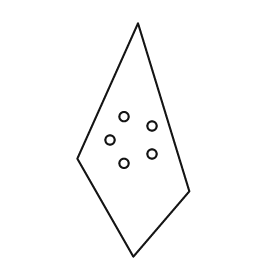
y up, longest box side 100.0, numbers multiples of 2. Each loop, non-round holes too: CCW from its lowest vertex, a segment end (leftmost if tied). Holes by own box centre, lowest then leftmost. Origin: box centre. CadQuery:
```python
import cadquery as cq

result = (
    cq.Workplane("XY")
    .moveTo(0.0, -50.0)
    .lineTo(24.0, -22.0)
    .lineTo(2.0, 50.0)
    .lineTo(-24.0, -8.0)
    .close()
    .moveTo(-4.0, -10.0)
    .circle(2.0)
    .moveTo(8.0, -6.0)
    .circle(2.0)
    .moveTo(-10.0, 0.0)
    .circle(2.0)
    .moveTo(8.0, 6.0)
    .circle(2.0)
    .moveTo(-4.0, 10.0)
    .circle(2.0)
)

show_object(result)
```